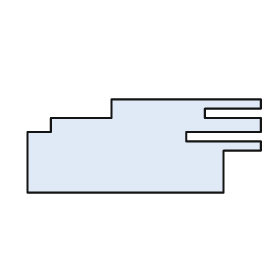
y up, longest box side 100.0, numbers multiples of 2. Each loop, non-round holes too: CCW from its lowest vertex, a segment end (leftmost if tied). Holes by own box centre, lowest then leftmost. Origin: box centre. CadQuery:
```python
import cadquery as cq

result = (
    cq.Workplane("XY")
    .moveTo(-50.0, -20.0)
    .lineTo(34.0, -20.0)
    .lineTo(34.0, -2.0)
    .lineTo(50.0, -2.0)
    .lineTo(50.0, 2.0)
    .lineTo(18.0, 2.0)
    .lineTo(18.0, 6.0)
    .lineTo(50.0, 6.0)
    .lineTo(50.0, 12.0)
    .lineTo(26.0, 12.0)
    .lineTo(26.0, 16.0)
    .lineTo(50.0, 16.0)
    .lineTo(50.0, 20.0)
    .lineTo(-14.0, 20.0)
    .lineTo(-14.0, 12.0)
    .lineTo(-40.0, 12.0)
    .lineTo(-40.0, 6.0)
    .lineTo(-50.0, 6.0)
    .close()
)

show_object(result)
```